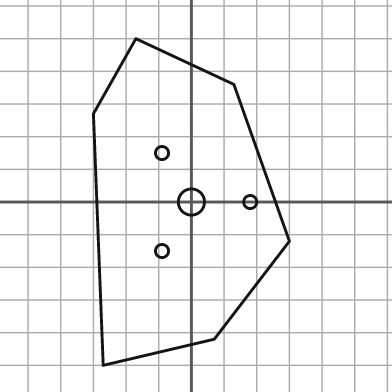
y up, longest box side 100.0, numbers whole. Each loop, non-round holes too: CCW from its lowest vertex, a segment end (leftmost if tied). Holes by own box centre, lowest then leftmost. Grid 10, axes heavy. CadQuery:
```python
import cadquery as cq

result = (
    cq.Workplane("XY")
    .moveTo(-27.0, -50.0)
    .lineTo(7.0, -42.0)
    .lineTo(30.0, -12.0)
    .lineTo(13.0, 36.0)
    .lineTo(-17.0, 50.0)
    .lineTo(-30.0, 27.0)
    .close()
    .moveTo(-9.0, -15.0)
    .circle(2.0)
    .moveTo(0.0, 0.0)
    .circle(4.0)
    .moveTo(18.0, 0.0)
    .circle(2.0)
    .moveTo(-9.0, 15.0)
    .circle(2.0)
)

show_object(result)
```